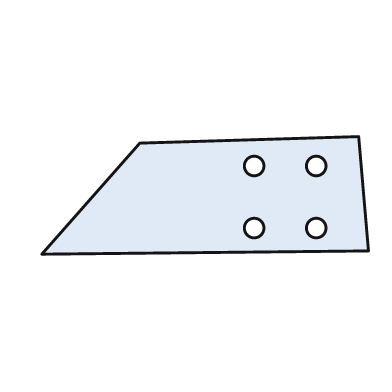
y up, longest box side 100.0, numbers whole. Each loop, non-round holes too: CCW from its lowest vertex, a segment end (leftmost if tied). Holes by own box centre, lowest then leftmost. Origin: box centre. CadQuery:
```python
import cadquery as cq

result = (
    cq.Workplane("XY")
    .moveTo(-50.0, -18.0)
    .lineTo(50.0, -17.0)
    .lineTo(47.0, 18.0)
    .lineTo(-20.0, 16.0)
    .close()
    .moveTo(15.0, -10.0)
    .circle(3.0)
    .moveTo(34.0, -10.0)
    .circle(3.0)
    .moveTo(15.0, 9.0)
    .circle(3.0)
    .moveTo(34.0, 9.0)
    .circle(3.0)
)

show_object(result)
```